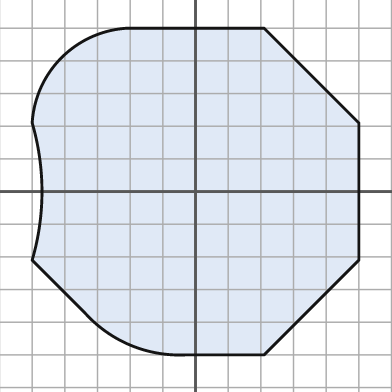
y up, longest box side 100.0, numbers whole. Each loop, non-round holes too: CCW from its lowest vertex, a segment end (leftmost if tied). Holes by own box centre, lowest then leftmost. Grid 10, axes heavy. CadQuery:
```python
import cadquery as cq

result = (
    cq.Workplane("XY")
    .moveTo(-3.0, -50.0)
    .lineTo(21.0, -50.0)
    .lineTo(50.0, -21.0)
    .lineTo(50.0, 21.0)
    .lineTo(21.0, 50.0)
    .lineTo(-21.0, 50.0)
    .threePointArc((-41.0, 41.0), (-50.0, 21.0))
    .threePointArc((-47.0, 0.0), (-50.0, -21.0))
    .lineTo(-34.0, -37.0)
    .threePointArc((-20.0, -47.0), (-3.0, -50.0))
    .close()
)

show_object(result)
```